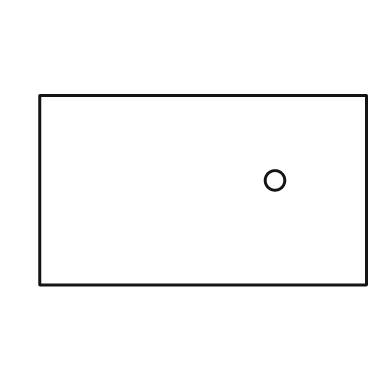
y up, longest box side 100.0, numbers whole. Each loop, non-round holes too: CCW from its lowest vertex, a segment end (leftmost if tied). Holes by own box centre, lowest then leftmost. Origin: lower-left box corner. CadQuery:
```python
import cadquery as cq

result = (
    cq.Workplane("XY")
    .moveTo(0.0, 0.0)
    .lineTo(100.0, 0.0)
    .lineTo(100.0, 58.0)
    .lineTo(0.0, 58.0)
    .close()
    .moveTo(72.0, 32.0)
    .circle(3.0)
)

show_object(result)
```